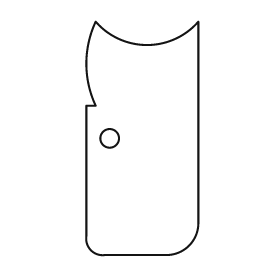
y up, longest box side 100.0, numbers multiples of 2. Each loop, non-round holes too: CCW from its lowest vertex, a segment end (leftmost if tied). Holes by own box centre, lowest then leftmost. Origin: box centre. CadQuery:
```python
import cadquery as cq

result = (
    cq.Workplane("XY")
    .moveTo(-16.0, -50.0)
    .lineTo(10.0, -50.0)
    .threePointArc((20.0, -46.0), (24.0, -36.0))
    .lineTo(24.0, 50.0)
    .threePointArc((2.0, 40.0), (-20.0, 50.0))
    .threePointArc((-24.0, 32.0), (-20.0, 14.0))
    .lineTo(-24.0, 14.0)
    .lineTo(-24.0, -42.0)
    .threePointArc((-22.0, -48.0), (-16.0, -50.0))
    .close()
    .moveTo(-14.0, 0.0)
    .circle(4.0)
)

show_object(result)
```